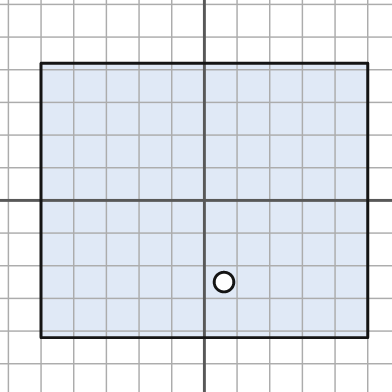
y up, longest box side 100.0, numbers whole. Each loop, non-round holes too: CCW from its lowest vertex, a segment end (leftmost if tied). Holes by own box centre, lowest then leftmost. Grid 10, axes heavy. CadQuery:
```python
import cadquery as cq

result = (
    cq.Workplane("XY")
    .moveTo(-50.0, -42.0)
    .lineTo(50.0, -42.0)
    .lineTo(50.0, 42.0)
    .lineTo(-50.0, 42.0)
    .close()
    .moveTo(6.0, -25.0)
    .circle(3.0)
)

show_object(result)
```